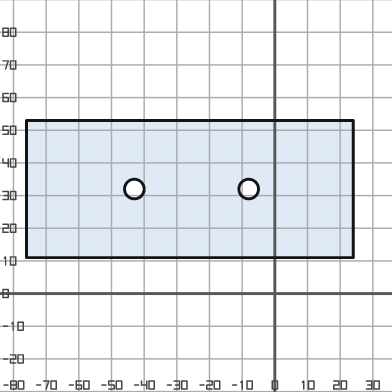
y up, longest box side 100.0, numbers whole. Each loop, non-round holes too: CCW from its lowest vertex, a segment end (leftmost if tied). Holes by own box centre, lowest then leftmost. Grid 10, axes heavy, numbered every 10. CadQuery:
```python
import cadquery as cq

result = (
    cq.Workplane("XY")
    .moveTo(-76.0, 11.0)
    .lineTo(24.0, 11.0)
    .lineTo(24.0, 53.0)
    .lineTo(-76.0, 53.0)
    .close()
    .moveTo(-43.0, 32.0)
    .circle(3.0)
    .moveTo(-8.0, 32.0)
    .circle(3.0)
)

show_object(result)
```